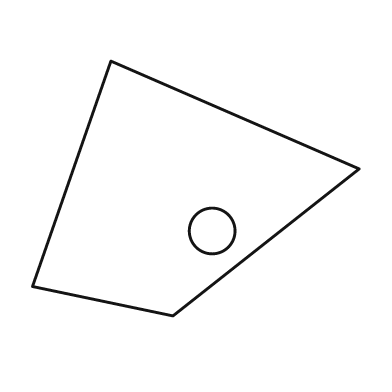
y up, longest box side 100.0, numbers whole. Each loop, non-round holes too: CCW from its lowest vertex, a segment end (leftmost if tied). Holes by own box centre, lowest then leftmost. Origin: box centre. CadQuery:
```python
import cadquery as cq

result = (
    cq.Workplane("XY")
    .moveTo(-7.0, -39.0)
    .lineTo(50.0, 6.0)
    .lineTo(-26.0, 39.0)
    .lineTo(-50.0, -30.0)
    .close()
    .moveTo(5.0, -13.0)
    .circle(7.0)
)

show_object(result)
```